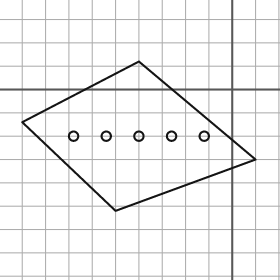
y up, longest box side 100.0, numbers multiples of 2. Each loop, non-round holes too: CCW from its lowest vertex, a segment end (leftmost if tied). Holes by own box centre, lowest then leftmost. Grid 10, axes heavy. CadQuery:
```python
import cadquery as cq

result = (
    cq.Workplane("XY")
    .moveTo(-50.0, -52.0)
    .lineTo(10.0, -30.0)
    .lineTo(-40.0, 12.0)
    .lineTo(-90.0, -14.0)
    .close()
    .moveTo(-68.0, -20.0)
    .circle(2.0)
    .moveTo(-54.0, -20.0)
    .circle(2.0)
    .moveTo(-40.0, -20.0)
    .circle(2.0)
    .moveTo(-26.0, -20.0)
    .circle(2.0)
    .moveTo(-12.0, -20.0)
    .circle(2.0)
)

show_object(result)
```